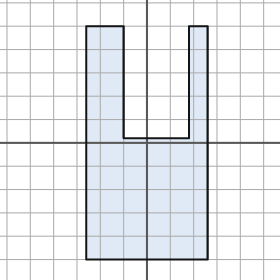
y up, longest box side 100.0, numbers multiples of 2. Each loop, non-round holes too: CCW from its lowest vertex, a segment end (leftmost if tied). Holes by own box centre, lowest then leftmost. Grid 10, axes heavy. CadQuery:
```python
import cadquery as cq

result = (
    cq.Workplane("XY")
    .moveTo(-26.0, -50.0)
    .lineTo(26.0, -50.0)
    .lineTo(26.0, 50.0)
    .lineTo(18.0, 50.0)
    .lineTo(18.0, 2.0)
    .lineTo(-10.0, 2.0)
    .lineTo(-10.0, 50.0)
    .lineTo(-26.0, 50.0)
    .close()
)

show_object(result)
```